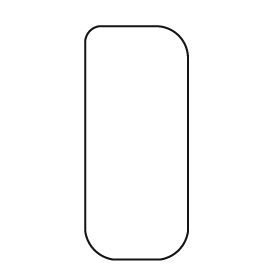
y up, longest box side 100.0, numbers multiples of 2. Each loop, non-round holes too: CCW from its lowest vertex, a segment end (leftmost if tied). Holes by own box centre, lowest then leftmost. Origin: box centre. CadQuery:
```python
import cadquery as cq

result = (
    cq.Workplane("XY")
    .moveTo(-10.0, -50.0)
    .lineTo(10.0, -50.0)
    .threePointArc((18.0, -46.0), (22.0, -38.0))
    .lineTo(22.0, 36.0)
    .threePointArc((18.0, 46.0), (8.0, 50.0))
    .lineTo(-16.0, 50.0)
    .threePointArc((-20.0, 48.0), (-22.0, 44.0))
    .lineTo(-22.0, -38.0)
    .threePointArc((-18.0, -46.0), (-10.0, -50.0))
    .close()
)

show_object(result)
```